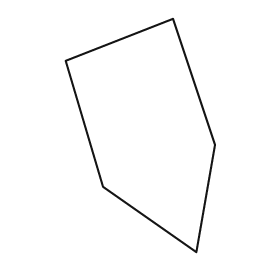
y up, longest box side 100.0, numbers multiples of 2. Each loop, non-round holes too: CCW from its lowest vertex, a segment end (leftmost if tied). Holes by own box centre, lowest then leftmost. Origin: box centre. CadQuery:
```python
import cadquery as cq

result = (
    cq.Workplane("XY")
    .moveTo(24.0, -50.0)
    .lineTo(32.0, -4.0)
    .lineTo(14.0, 50.0)
    .lineTo(-32.0, 32.0)
    .lineTo(-16.0, -22.0)
    .close()
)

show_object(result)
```